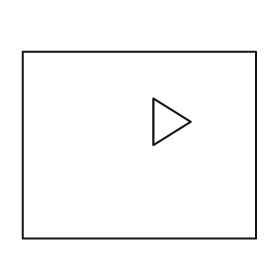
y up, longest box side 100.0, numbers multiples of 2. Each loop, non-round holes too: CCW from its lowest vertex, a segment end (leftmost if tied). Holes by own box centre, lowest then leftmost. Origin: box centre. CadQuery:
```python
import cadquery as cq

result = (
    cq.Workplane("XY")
    .moveTo(-50.0, -40.0)
    .lineTo(50.0, -40.0)
    .lineTo(50.0, 40.0)
    .lineTo(-50.0, 40.0)
    .close()
    .moveTo(6.0, 0.0)
    .lineTo(22.0, 10.0)
    .lineTo(6.0, 20.0)
    .close()
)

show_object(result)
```